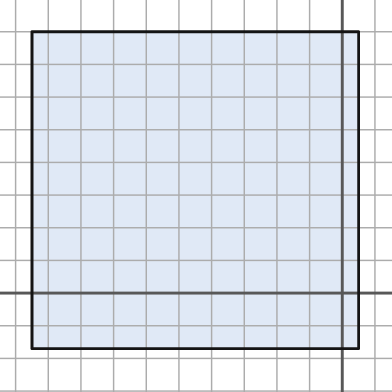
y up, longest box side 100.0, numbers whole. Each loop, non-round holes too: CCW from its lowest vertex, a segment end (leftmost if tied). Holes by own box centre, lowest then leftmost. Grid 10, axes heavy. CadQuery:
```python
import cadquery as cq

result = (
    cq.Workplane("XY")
    .moveTo(-95.0, -17.0)
    .lineTo(5.0, -17.0)
    .lineTo(5.0, 80.0)
    .lineTo(-95.0, 80.0)
    .close()
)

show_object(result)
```